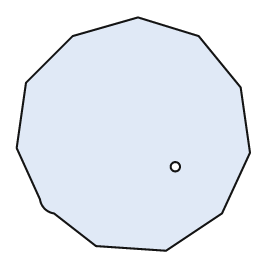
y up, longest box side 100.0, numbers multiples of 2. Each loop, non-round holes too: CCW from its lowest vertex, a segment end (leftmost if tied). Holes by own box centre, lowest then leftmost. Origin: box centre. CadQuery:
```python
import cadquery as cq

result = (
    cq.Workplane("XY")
    .moveTo(14.0, -50.0)
    .lineTo(38.0, -34.0)
    .lineTo(50.0, -8.0)
    .lineTo(46.0, 20.0)
    .lineTo(28.0, 42.0)
    .lineTo(2.0, 50.0)
    .lineTo(-26.0, 42.0)
    .lineTo(-46.0, 22.0)
    .lineTo(-50.0, -6.0)
    .lineTo(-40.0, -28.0)
    .threePointArc((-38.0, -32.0), (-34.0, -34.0))
    .lineTo(-16.0, -48.0)
    .close()
    .moveTo(18.0, -14.0)
    .circle(2.0)
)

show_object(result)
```